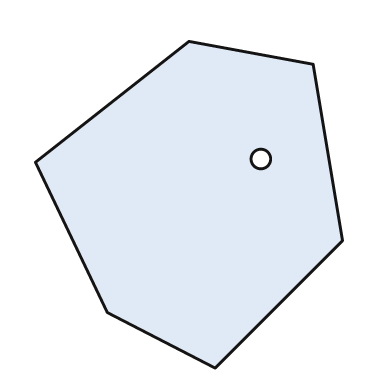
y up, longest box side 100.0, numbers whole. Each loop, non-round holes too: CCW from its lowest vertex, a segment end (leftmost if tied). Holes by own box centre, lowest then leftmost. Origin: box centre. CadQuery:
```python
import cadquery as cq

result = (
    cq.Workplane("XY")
    .moveTo(8.0, -50.0)
    .lineTo(47.0, -11.0)
    .lineTo(38.0, 43.0)
    .lineTo(0.0, 50.0)
    .lineTo(-47.0, 13.0)
    .lineTo(-25.0, -33.0)
    .close()
    .moveTo(22.0, 14.0)
    .circle(3.0)
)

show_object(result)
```